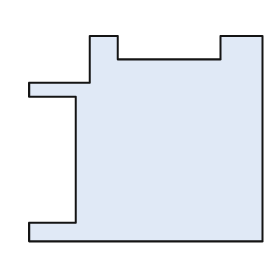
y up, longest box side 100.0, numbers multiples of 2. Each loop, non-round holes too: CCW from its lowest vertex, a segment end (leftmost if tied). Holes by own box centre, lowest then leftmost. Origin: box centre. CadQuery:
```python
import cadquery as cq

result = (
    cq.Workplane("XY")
    .moveTo(-50.0, -44.0)
    .lineTo(50.0, -44.0)
    .lineTo(50.0, 44.0)
    .lineTo(32.0, 44.0)
    .lineTo(32.0, 34.0)
    .lineTo(-12.0, 34.0)
    .lineTo(-12.0, 44.0)
    .lineTo(-24.0, 44.0)
    .lineTo(-24.0, 24.0)
    .lineTo(-50.0, 24.0)
    .lineTo(-50.0, 18.0)
    .lineTo(-30.0, 18.0)
    .lineTo(-30.0, -36.0)
    .lineTo(-50.0, -36.0)
    .close()
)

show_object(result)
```